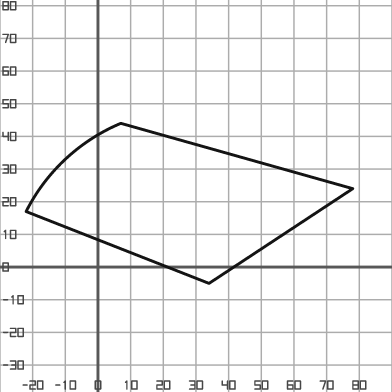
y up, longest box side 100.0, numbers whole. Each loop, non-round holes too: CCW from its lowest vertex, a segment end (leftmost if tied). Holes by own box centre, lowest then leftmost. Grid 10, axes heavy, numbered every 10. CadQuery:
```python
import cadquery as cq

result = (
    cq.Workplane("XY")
    .moveTo(34.0, -5.0)
    .lineTo(78.0, 24.0)
    .lineTo(7.0, 44.0)
    .threePointArc((-10.0, 33.0), (-22.0, 17.0))
    .close()
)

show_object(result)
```